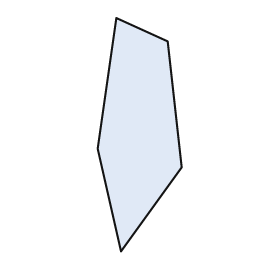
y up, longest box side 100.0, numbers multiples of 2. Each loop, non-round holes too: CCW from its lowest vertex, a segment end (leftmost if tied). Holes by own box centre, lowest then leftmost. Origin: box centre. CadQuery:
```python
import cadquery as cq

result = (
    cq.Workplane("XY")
    .moveTo(-8.0, -50.0)
    .lineTo(18.0, -14.0)
    .lineTo(12.0, 40.0)
    .lineTo(-10.0, 50.0)
    .lineTo(-18.0, -6.0)
    .close()
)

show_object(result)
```